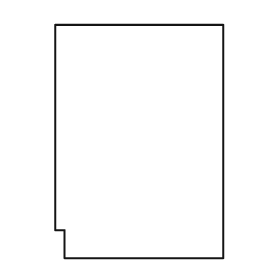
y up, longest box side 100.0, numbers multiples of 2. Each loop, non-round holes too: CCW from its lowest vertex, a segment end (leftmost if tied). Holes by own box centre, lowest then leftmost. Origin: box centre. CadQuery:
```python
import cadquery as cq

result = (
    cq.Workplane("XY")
    .moveTo(-32.0, -50.0)
    .lineTo(36.0, -50.0)
    .lineTo(36.0, 50.0)
    .lineTo(-36.0, 50.0)
    .lineTo(-36.0, -38.0)
    .lineTo(-32.0, -38.0)
    .close()
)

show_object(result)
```